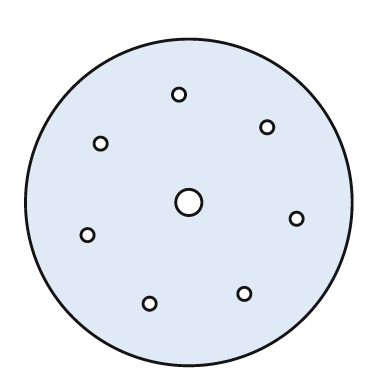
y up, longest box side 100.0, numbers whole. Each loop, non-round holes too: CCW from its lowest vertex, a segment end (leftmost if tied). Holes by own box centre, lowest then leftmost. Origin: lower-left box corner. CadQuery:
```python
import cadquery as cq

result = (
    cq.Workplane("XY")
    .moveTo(50.0, 50.0)
    .circle(50.0)
    .moveTo(38.0, 19.0)
    .circle(2.0)
    .moveTo(67.0, 22.0)
    .circle(2.0)
    .moveTo(19.0, 40.0)
    .circle(2.0)
    .moveTo(83.0, 45.0)
    .circle(2.0)
    .moveTo(50.0, 50.0)
    .circle(4.0)
    .moveTo(23.0, 68.0)
    .circle(2.0)
    .moveTo(74.0, 73.0)
    .circle(2.0)
    .moveTo(47.0, 83.0)
    .circle(2.0)
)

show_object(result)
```